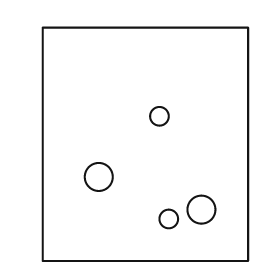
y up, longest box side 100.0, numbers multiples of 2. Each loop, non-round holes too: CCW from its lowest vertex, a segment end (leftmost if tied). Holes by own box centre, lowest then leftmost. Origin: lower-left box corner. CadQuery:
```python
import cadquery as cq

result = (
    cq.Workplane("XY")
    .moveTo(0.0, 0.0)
    .lineTo(88.0, 0.0)
    .lineTo(88.0, 100.0)
    .lineTo(0.0, 100.0)
    .close()
    .moveTo(54.0, 18.0)
    .circle(4.0)
    .moveTo(68.0, 22.0)
    .circle(6.0)
    .moveTo(24.0, 36.0)
    .circle(6.0)
    .moveTo(50.0, 62.0)
    .circle(4.0)
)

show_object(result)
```